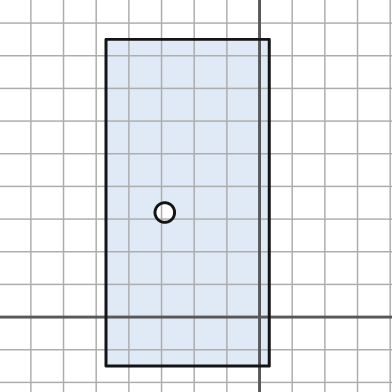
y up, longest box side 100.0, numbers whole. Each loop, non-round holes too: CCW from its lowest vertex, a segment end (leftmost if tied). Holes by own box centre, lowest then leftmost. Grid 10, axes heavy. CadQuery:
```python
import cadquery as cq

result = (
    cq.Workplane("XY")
    .moveTo(-47.0, -15.0)
    .lineTo(3.0, -15.0)
    .lineTo(3.0, 85.0)
    .lineTo(-47.0, 85.0)
    .close()
    .moveTo(-29.0, 32.0)
    .circle(3.0)
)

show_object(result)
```